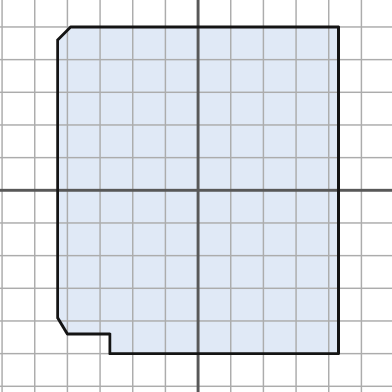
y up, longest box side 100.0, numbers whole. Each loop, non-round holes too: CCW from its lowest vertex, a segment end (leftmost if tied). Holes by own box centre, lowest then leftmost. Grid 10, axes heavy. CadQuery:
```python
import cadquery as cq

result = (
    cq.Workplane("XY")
    .moveTo(-27.0, -50.0)
    .lineTo(43.0, -50.0)
    .lineTo(43.0, 50.0)
    .lineTo(-39.0, 50.0)
    .lineTo(-43.0, 46.0)
    .lineTo(-43.0, -39.0)
    .lineTo(-40.0, -44.0)
    .lineTo(-27.0, -44.0)
    .close()
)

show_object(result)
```